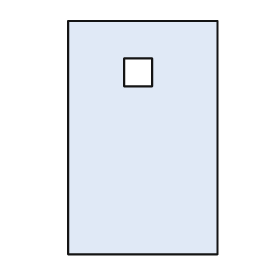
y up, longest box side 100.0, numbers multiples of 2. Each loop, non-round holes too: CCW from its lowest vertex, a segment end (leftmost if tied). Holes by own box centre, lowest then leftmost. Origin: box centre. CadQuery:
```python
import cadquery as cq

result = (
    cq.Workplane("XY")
    .moveTo(-32.0, -50.0)
    .lineTo(32.0, -50.0)
    .lineTo(32.0, 50.0)
    .lineTo(-32.0, 50.0)
    .close()
    .moveTo(-8.0, 22.0)
    .lineTo(4.0, 22.0)
    .lineTo(4.0, 34.0)
    .lineTo(-8.0, 34.0)
    .close()
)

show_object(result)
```